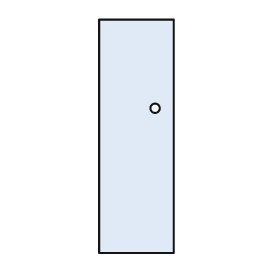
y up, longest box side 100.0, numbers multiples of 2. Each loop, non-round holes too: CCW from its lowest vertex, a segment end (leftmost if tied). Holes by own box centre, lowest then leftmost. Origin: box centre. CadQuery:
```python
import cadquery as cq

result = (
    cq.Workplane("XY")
    .moveTo(-16.0, -50.0)
    .lineTo(16.0, -50.0)
    .lineTo(16.0, 50.0)
    .lineTo(-16.0, 50.0)
    .close()
    .moveTo(8.0, 12.0)
    .circle(2.0)
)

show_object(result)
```